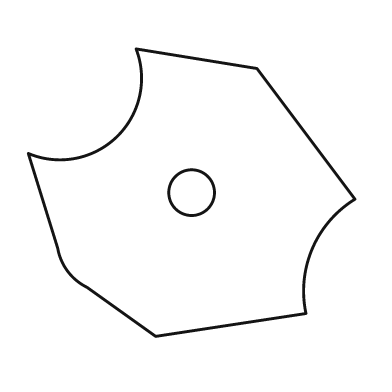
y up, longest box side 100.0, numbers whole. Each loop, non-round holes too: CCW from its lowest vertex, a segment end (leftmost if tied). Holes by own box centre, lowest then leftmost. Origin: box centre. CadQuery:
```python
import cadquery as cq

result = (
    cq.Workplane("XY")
    .moveTo(-11.0, -44.0)
    .lineTo(35.0, -37.0)
    .threePointArc((37.0, -17.0), (50.0, -2.0))
    .lineTo(20.0, 38.0)
    .lineTo(-17.0, 44.0)
    .threePointArc((-23.0, 17.0), (-50.0, 12.0))
    .lineTo(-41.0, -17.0)
    .threePointArc((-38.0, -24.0), (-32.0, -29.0))
    .close()
    .moveTo(0.0, 0.0)
    .circle(7.0)
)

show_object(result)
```